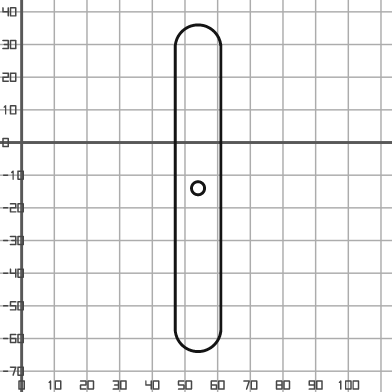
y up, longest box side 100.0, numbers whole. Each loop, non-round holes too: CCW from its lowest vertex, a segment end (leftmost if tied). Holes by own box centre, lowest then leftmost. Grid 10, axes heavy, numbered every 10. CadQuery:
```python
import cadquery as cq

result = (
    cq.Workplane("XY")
    .moveTo(47.0, -57.0)
    .threePointArc((54.0, -64.0), (61.0, -57.0))
    .lineTo(61.0, 29.0)
    .threePointArc((54.0, 36.0), (47.0, 29.0))
    .close()
    .moveTo(54.0, -14.0)
    .circle(2.0)
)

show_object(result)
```